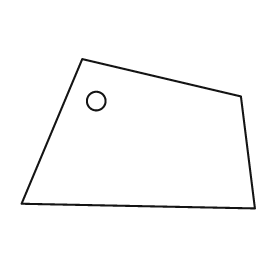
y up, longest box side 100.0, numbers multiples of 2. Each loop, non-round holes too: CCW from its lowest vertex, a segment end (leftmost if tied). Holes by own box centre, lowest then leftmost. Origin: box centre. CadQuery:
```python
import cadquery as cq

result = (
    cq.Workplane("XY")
    .moveTo(50.0, -32.0)
    .lineTo(44.0, 16.0)
    .lineTo(-24.0, 32.0)
    .lineTo(-50.0, -30.0)
    .close()
    .moveTo(-18.0, 14.0)
    .circle(4.0)
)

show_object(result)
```